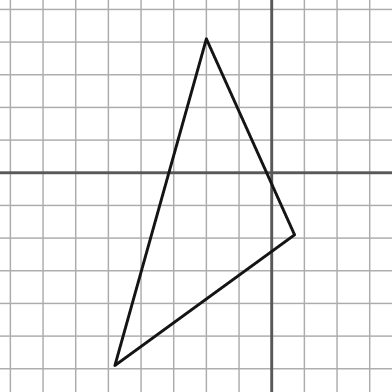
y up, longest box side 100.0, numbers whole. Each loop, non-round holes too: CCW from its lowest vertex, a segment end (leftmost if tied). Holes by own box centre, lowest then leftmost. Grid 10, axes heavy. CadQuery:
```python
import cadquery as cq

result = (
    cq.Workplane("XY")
    .moveTo(-48.0, -59.0)
    .lineTo(7.0, -19.0)
    .lineTo(-20.0, 41.0)
    .close()
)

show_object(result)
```